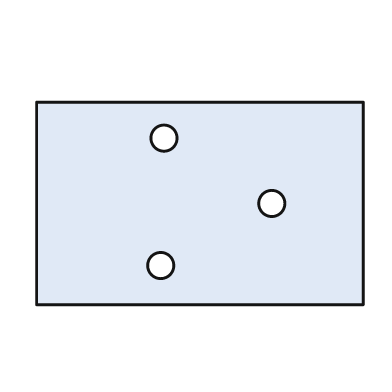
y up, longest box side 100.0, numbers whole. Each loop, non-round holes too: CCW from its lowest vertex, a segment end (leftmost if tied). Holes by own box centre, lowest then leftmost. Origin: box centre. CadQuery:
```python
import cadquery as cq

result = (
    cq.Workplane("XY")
    .moveTo(-50.0, -31.0)
    .lineTo(50.0, -31.0)
    .lineTo(50.0, 31.0)
    .lineTo(-50.0, 31.0)
    .close()
    .moveTo(-12.0, -19.0)
    .circle(4.0)
    .moveTo(22.0, 0.0)
    .circle(4.0)
    .moveTo(-11.0, 20.0)
    .circle(4.0)
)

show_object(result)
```